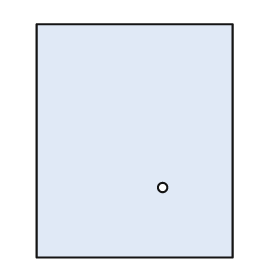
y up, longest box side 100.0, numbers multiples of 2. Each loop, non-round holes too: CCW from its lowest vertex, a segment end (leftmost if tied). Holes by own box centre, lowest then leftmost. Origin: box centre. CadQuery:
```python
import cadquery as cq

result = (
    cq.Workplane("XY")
    .moveTo(-42.0, -50.0)
    .lineTo(42.0, -50.0)
    .lineTo(42.0, 50.0)
    .lineTo(-42.0, 50.0)
    .close()
    .moveTo(12.0, -20.0)
    .circle(2.0)
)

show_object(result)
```